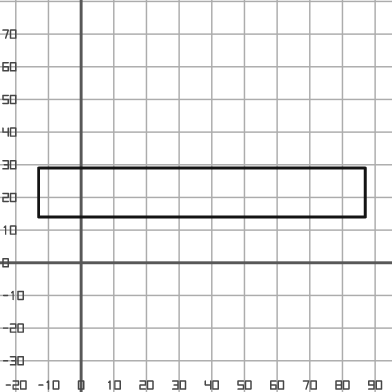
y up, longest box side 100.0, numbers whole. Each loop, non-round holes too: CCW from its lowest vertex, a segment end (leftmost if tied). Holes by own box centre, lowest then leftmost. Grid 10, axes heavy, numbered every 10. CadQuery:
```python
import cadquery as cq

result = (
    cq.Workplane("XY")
    .moveTo(-13.0, 14.0)
    .lineTo(87.0, 14.0)
    .lineTo(87.0, 29.0)
    .lineTo(-13.0, 29.0)
    .close()
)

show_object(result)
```